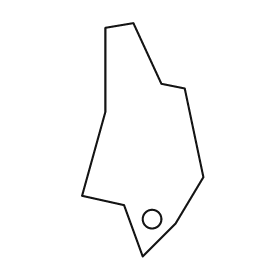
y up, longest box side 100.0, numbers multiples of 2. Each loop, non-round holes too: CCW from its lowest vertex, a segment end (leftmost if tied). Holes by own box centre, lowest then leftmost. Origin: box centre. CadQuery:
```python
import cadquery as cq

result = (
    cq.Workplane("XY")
    .moveTo(0.0, -50.0)
    .lineTo(14.0, -36.0)
    .lineTo(26.0, -16.0)
    .lineTo(18.0, 22.0)
    .lineTo(8.0, 24.0)
    .lineTo(-4.0, 50.0)
    .lineTo(-16.0, 48.0)
    .lineTo(-16.0, 12.0)
    .lineTo(-26.0, -24.0)
    .lineTo(-8.0, -28.0)
    .close()
    .moveTo(4.0, -34.0)
    .circle(4.0)
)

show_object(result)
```